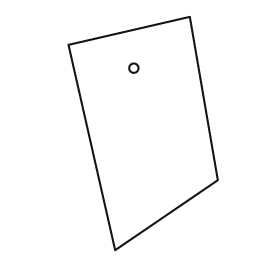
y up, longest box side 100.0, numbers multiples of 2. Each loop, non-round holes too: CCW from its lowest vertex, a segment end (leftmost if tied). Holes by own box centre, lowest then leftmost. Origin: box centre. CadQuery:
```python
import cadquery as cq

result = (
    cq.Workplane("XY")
    .moveTo(-12.0, -50.0)
    .lineTo(32.0, -20.0)
    .lineTo(20.0, 50.0)
    .lineTo(-32.0, 38.0)
    .close()
    .moveTo(-4.0, 28.0)
    .circle(2.0)
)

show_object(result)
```